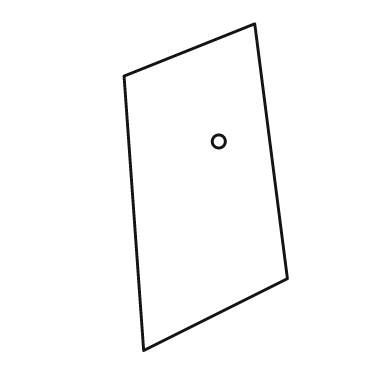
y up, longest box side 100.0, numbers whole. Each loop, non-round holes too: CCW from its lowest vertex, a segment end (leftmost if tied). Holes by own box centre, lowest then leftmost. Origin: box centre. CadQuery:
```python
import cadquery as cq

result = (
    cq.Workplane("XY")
    .moveTo(-19.0, -50.0)
    .lineTo(25.0, -28.0)
    .lineTo(15.0, 50.0)
    .lineTo(-25.0, 34.0)
    .close()
    .moveTo(4.0, 14.0)
    .circle(2.0)
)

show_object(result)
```